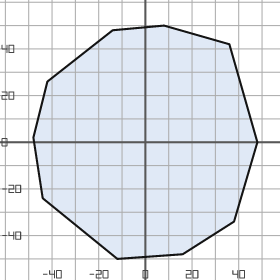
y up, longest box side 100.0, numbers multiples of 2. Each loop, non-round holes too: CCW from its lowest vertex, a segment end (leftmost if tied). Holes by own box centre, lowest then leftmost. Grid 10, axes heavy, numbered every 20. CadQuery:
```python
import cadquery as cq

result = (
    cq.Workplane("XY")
    .moveTo(-12.0, -50.0)
    .lineTo(16.0, -48.0)
    .lineTo(38.0, -34.0)
    .lineTo(48.0, 0.0)
    .lineTo(36.0, 42.0)
    .lineTo(8.0, 50.0)
    .lineTo(-14.0, 48.0)
    .lineTo(-42.0, 26.0)
    .lineTo(-48.0, 2.0)
    .lineTo(-44.0, -24.0)
    .close()
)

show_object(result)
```